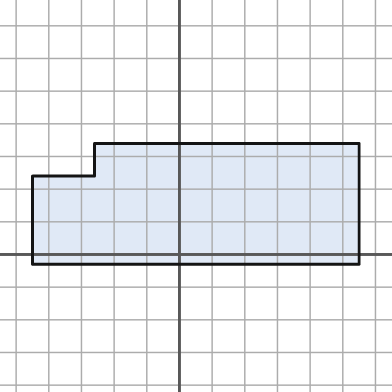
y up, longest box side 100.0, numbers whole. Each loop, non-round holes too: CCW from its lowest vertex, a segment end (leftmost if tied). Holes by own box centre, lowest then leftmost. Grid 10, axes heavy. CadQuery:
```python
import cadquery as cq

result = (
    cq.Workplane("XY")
    .moveTo(-45.0, -3.0)
    .lineTo(55.0, -3.0)
    .lineTo(55.0, 34.0)
    .lineTo(-26.0, 34.0)
    .lineTo(-26.0, 24.0)
    .lineTo(-45.0, 24.0)
    .close()
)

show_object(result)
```